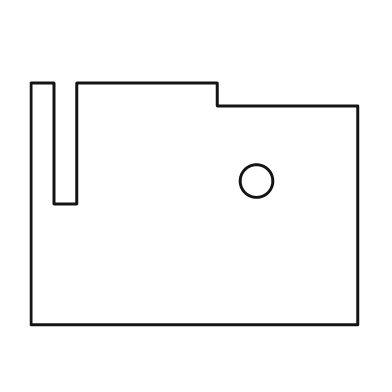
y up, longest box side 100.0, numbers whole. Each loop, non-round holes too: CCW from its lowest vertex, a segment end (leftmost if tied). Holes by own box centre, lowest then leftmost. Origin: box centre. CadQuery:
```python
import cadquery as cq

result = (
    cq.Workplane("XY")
    .moveTo(-50.0, -37.0)
    .lineTo(50.0, -37.0)
    .lineTo(50.0, 30.0)
    .lineTo(7.0, 30.0)
    .lineTo(7.0, 37.0)
    .lineTo(-36.0, 37.0)
    .lineTo(-36.0, 0.0)
    .lineTo(-43.0, 0.0)
    .lineTo(-43.0, 37.0)
    .lineTo(-50.0, 37.0)
    .close()
    .moveTo(19.0, 7.0)
    .circle(5.0)
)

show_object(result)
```